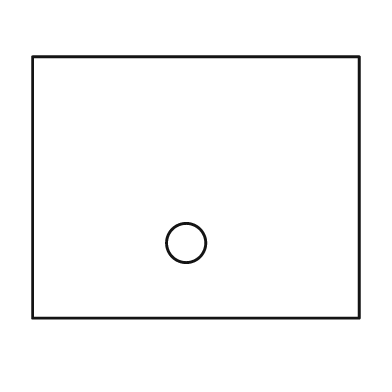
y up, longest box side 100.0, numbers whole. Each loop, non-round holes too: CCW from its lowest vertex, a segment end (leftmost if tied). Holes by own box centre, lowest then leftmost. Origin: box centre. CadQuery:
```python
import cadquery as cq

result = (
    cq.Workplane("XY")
    .moveTo(-50.0, -40.0)
    .lineTo(50.0, -40.0)
    .lineTo(50.0, 40.0)
    .lineTo(-50.0, 40.0)
    .close()
    .moveTo(-3.0, -17.0)
    .circle(6.0)
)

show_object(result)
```